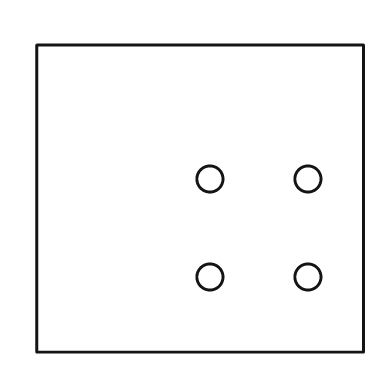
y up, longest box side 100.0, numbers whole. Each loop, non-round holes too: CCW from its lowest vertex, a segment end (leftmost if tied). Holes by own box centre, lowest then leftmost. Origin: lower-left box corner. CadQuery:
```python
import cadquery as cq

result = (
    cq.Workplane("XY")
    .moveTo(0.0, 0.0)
    .lineTo(100.0, 0.0)
    .lineTo(100.0, 94.0)
    .lineTo(0.0, 94.0)
    .close()
    .moveTo(53.0, 23.0)
    .circle(4.0)
    .moveTo(83.0, 23.0)
    .circle(4.0)
    .moveTo(53.0, 53.0)
    .circle(4.0)
    .moveTo(83.0, 53.0)
    .circle(4.0)
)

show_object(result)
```